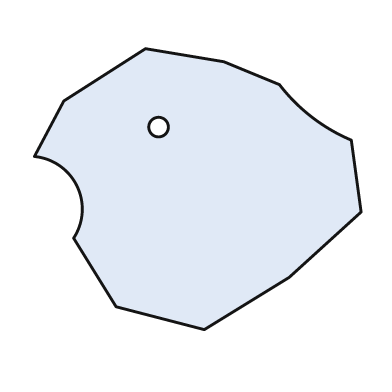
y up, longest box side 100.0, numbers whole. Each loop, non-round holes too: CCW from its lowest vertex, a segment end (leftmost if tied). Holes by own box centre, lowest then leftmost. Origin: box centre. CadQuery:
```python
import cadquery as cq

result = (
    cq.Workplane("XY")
    .moveTo(2.0, -43.0)
    .lineTo(28.0, -27.0)
    .lineTo(50.0, -7.0)
    .lineTo(47.0, 15.0)
    .threePointArc((35.0, 22.0), (25.0, 32.0))
    .lineTo(8.0, 39.0)
    .lineTo(-16.0, 43.0)
    .lineTo(-41.0, 27.0)
    .lineTo(-50.0, 10.0)
    .threePointArc((-37.0, 1.0), (-38.0, -15.0))
    .lineTo(-25.0, -36.0)
    .close()
    .moveTo(-12.0, 19.0)
    .circle(3.0)
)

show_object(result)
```